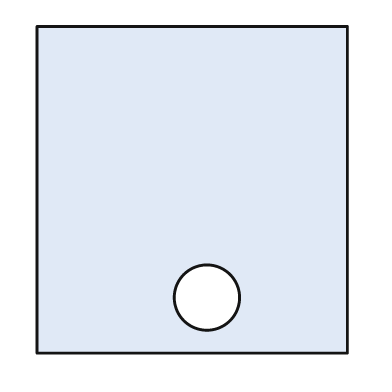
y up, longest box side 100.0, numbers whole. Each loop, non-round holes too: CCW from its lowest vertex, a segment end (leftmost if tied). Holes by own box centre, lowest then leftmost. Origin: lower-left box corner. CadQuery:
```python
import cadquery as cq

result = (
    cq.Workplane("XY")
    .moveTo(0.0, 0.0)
    .lineTo(95.0, 0.0)
    .lineTo(95.0, 100.0)
    .lineTo(0.0, 100.0)
    .close()
    .moveTo(52.0, 17.0)
    .circle(10.0)
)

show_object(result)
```